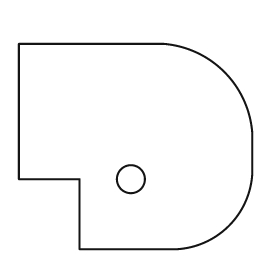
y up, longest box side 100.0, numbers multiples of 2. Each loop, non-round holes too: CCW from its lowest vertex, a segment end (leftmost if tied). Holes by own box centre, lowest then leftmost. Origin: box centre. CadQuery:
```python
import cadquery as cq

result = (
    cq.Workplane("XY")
    .moveTo(-24.0, -44.0)
    .lineTo(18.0, -44.0)
    .threePointArc((40.0, -34.0), (50.0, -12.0))
    .lineTo(50.0, 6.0)
    .threePointArc((38.0, 32.0), (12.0, 44.0))
    .lineTo(-50.0, 44.0)
    .lineTo(-50.0, -14.0)
    .lineTo(-24.0, -14.0)
    .close()
    .moveTo(-2.0, -14.0)
    .circle(6.0)
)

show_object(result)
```